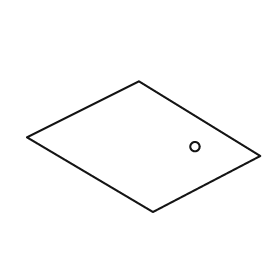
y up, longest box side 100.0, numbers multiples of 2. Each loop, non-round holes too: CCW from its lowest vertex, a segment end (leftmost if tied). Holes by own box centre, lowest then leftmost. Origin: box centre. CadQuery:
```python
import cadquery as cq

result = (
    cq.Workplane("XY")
    .moveTo(4.0, -28.0)
    .lineTo(50.0, -4.0)
    .lineTo(-2.0, 28.0)
    .lineTo(-50.0, 4.0)
    .close()
    .moveTo(22.0, 0.0)
    .circle(2.0)
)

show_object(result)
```